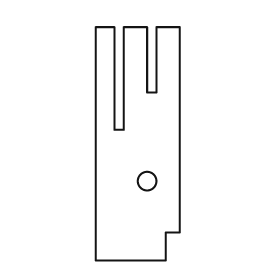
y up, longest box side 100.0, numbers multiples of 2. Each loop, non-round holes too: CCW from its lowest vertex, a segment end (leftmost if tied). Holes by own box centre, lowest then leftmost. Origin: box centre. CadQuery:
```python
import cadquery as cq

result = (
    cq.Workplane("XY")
    .moveTo(-18.0, -50.0)
    .lineTo(12.0, -50.0)
    .lineTo(12.0, -38.0)
    .lineTo(18.0, -38.0)
    .lineTo(18.0, 50.0)
    .lineTo(8.0, 50.0)
    .lineTo(8.0, 22.0)
    .lineTo(4.0, 22.0)
    .lineTo(4.0, 50.0)
    .lineTo(-6.0, 50.0)
    .lineTo(-6.0, 6.0)
    .lineTo(-10.0, 6.0)
    .lineTo(-10.0, 50.0)
    .lineTo(-18.0, 50.0)
    .close()
    .moveTo(4.0, -16.0)
    .circle(4.0)
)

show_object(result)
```